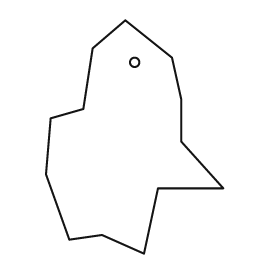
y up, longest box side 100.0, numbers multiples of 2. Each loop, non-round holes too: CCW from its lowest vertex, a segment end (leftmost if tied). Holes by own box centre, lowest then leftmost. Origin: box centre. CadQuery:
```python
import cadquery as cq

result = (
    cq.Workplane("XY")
    .moveTo(4.0, -50.0)
    .lineTo(10.0, -22.0)
    .lineTo(38.0, -22.0)
    .lineTo(20.0, -2.0)
    .lineTo(20.0, 16.0)
    .lineTo(16.0, 34.0)
    .lineTo(-4.0, 50.0)
    .lineTo(-18.0, 38.0)
    .lineTo(-22.0, 12.0)
    .lineTo(-36.0, 8.0)
    .lineTo(-38.0, -16.0)
    .lineTo(-28.0, -44.0)
    .lineTo(-14.0, -42.0)
    .close()
    .moveTo(0.0, 32.0)
    .circle(2.0)
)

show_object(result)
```